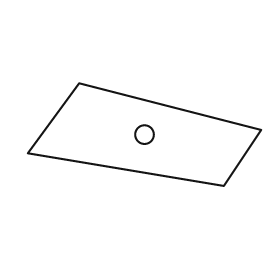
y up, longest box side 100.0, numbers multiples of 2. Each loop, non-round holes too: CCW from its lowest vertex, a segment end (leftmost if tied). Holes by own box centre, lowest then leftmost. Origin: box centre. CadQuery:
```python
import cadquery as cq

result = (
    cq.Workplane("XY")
    .moveTo(34.0, -22.0)
    .lineTo(50.0, 2.0)
    .lineTo(-28.0, 22.0)
    .lineTo(-50.0, -8.0)
    .close()
    .moveTo(0.0, 0.0)
    .circle(4.0)
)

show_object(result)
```